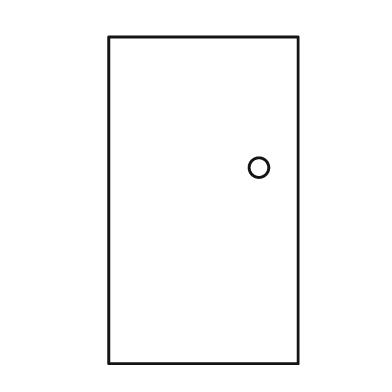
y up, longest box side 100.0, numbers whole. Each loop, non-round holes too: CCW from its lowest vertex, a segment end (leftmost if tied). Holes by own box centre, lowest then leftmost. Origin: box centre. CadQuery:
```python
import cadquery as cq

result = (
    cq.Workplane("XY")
    .moveTo(-29.0, -50.0)
    .lineTo(29.0, -50.0)
    .lineTo(29.0, 50.0)
    .lineTo(-29.0, 50.0)
    .close()
    .moveTo(17.0, 10.0)
    .circle(3.0)
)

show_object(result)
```